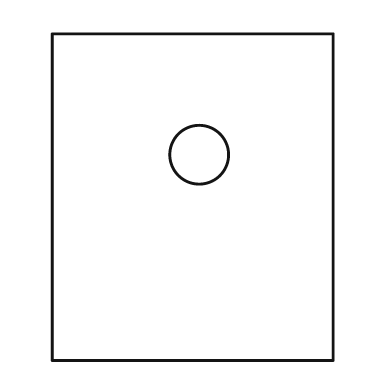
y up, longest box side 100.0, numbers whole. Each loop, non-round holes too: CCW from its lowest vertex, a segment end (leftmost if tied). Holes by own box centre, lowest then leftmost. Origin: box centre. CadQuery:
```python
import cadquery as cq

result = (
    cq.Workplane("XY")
    .moveTo(-43.0, -50.0)
    .lineTo(43.0, -50.0)
    .lineTo(43.0, 50.0)
    .lineTo(-43.0, 50.0)
    .close()
    .moveTo(2.0, 13.0)
    .circle(9.0)
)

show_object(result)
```